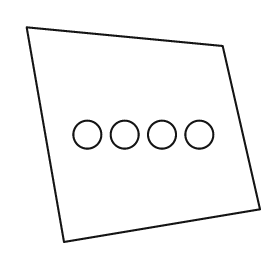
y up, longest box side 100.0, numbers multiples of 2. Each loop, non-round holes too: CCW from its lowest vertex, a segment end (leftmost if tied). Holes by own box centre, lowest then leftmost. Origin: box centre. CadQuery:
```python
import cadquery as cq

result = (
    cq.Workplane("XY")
    .moveTo(-34.0, -46.0)
    .lineTo(50.0, -32.0)
    .lineTo(34.0, 38.0)
    .lineTo(-50.0, 46.0)
    .close()
    .moveTo(-24.0, 0.0)
    .circle(6.0)
    .moveTo(-8.0, 0.0)
    .circle(6.0)
    .moveTo(8.0, 0.0)
    .circle(6.0)
    .moveTo(24.0, 0.0)
    .circle(6.0)
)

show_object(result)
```